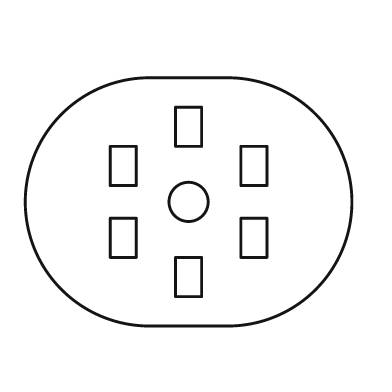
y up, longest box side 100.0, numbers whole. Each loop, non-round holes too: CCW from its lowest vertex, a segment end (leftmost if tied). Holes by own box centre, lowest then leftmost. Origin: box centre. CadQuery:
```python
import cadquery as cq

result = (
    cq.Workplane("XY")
    .moveTo(-12.0, -38.0)
    .lineTo(12.0, -38.0)
    .threePointArc((50.0, 0.0), (12.0, 38.0))
    .lineTo(-12.0, 38.0)
    .threePointArc((-50.0, 0.0), (-12.0, -38.0))
    .close()
    .moveTo(-4.0, -29.0)
    .lineTo(4.0, -29.0)
    .lineTo(4.0, -17.0)
    .lineTo(-4.0, -17.0)
    .close()
    .moveTo(-24.0, -17.0)
    .lineTo(-16.0, -17.0)
    .lineTo(-16.0, -5.0)
    .lineTo(-24.0, -5.0)
    .close()
    .moveTo(16.0, -17.0)
    .lineTo(24.0, -17.0)
    .lineTo(24.0, -5.0)
    .lineTo(16.0, -5.0)
    .close()
    .moveTo(0.0, 0.0)
    .circle(6.0)
    .moveTo(-24.0, 5.0)
    .lineTo(-16.0, 5.0)
    .lineTo(-16.0, 17.0)
    .lineTo(-24.0, 17.0)
    .close()
    .moveTo(16.0, 5.0)
    .lineTo(24.0, 5.0)
    .lineTo(24.0, 17.0)
    .lineTo(16.0, 17.0)
    .close()
    .moveTo(-4.0, 17.0)
    .lineTo(4.0, 17.0)
    .lineTo(4.0, 29.0)
    .lineTo(-4.0, 29.0)
    .close()
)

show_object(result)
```